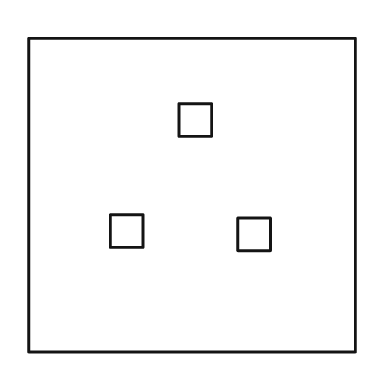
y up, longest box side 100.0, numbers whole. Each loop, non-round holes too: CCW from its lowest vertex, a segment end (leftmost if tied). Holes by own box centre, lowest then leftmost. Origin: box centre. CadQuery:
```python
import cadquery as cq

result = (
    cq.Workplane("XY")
    .moveTo(-50.0, -48.0)
    .lineTo(50.0, -48.0)
    .lineTo(50.0, 48.0)
    .lineTo(-50.0, 48.0)
    .close()
    .moveTo(14.0, -17.0)
    .lineTo(24.0, -17.0)
    .lineTo(24.0, -7.0)
    .lineTo(14.0, -7.0)
    .close()
    .moveTo(-25.0, -16.0)
    .lineTo(-15.0, -16.0)
    .lineTo(-15.0, -6.0)
    .lineTo(-25.0, -6.0)
    .close()
    .moveTo(-4.0, 18.0)
    .lineTo(6.0, 18.0)
    .lineTo(6.0, 28.0)
    .lineTo(-4.0, 28.0)
    .close()
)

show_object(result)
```